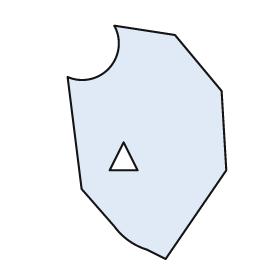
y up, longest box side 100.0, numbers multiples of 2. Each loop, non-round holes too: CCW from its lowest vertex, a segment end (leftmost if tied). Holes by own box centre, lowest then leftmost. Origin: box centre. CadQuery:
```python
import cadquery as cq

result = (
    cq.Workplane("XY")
    .moveTo(8.0, -50.0)
    .lineTo(34.0, -12.0)
    .lineTo(32.0, 22.0)
    .lineTo(12.0, 46.0)
    .lineTo(-14.0, 50.0)
    .threePointArc((-16.0, 32.0), (-34.0, 28.0))
    .lineTo(-28.0, -20.0)
    .lineTo(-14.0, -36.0)
    .threePointArc((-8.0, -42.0), (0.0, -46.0))
    .close()
    .moveTo(-16.0, -12.0)
    .lineTo(-4.0, -12.0)
    .lineTo(-10.0, 0.0)
    .close()
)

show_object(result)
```